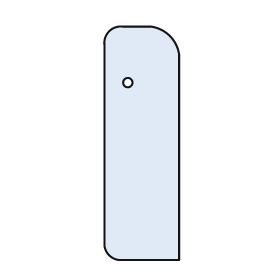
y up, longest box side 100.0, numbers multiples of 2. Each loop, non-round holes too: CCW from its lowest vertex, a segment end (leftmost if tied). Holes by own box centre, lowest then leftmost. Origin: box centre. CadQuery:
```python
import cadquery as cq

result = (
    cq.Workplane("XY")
    .moveTo(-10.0, -50.0)
    .lineTo(16.0, -50.0)
    .lineTo(16.0, 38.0)
    .threePointArc((12.0, 46.0), (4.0, 50.0))
    .lineTo(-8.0, 50.0)
    .threePointArc((-14.0, 48.0), (-16.0, 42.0))
    .lineTo(-16.0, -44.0)
    .threePointArc((-14.0, -48.0), (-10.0, -50.0))
    .close()
    .moveTo(-6.0, 26.0)
    .circle(2.0)
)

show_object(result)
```